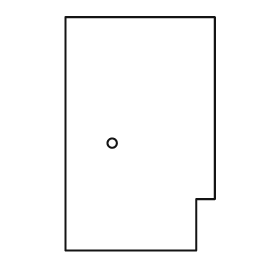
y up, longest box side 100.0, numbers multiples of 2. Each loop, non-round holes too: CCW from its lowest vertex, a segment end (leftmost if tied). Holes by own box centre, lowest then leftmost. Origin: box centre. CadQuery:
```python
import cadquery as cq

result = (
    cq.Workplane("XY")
    .moveTo(-32.0, -50.0)
    .lineTo(24.0, -50.0)
    .lineTo(24.0, -28.0)
    .lineTo(32.0, -28.0)
    .lineTo(32.0, 50.0)
    .lineTo(-32.0, 50.0)
    .close()
    .moveTo(-12.0, -4.0)
    .circle(2.0)
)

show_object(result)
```